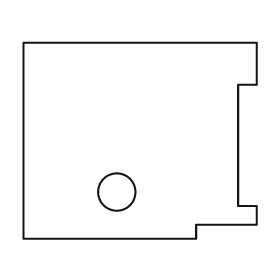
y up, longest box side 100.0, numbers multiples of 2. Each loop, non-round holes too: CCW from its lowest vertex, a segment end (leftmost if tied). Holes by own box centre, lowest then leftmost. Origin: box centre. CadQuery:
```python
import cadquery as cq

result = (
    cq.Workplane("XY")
    .moveTo(-50.0, -42.0)
    .lineTo(24.0, -42.0)
    .lineTo(24.0, -36.0)
    .lineTo(50.0, -36.0)
    .lineTo(50.0, -28.0)
    .lineTo(42.0, -28.0)
    .lineTo(42.0, 24.0)
    .lineTo(50.0, 24.0)
    .lineTo(50.0, 42.0)
    .lineTo(-50.0, 42.0)
    .close()
    .moveTo(-10.0, -22.0)
    .circle(8.0)
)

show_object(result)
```